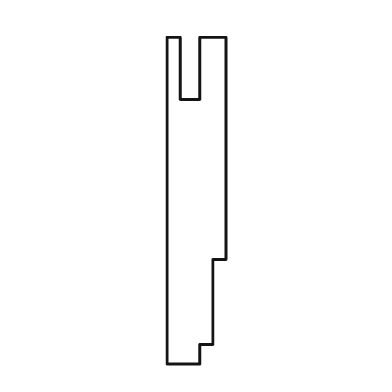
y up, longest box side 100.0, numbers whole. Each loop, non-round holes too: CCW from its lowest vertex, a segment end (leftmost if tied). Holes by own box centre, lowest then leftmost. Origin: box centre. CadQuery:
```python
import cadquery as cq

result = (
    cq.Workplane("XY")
    .moveTo(-9.0, -50.0)
    .lineTo(1.0, -50.0)
    .lineTo(1.0, -44.0)
    .lineTo(5.0, -44.0)
    .lineTo(5.0, -18.0)
    .lineTo(9.0, -18.0)
    .lineTo(9.0, 50.0)
    .lineTo(1.0, 50.0)
    .lineTo(1.0, 31.0)
    .lineTo(-5.0, 31.0)
    .lineTo(-5.0, 50.0)
    .lineTo(-9.0, 50.0)
    .close()
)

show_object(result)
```